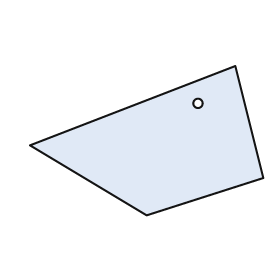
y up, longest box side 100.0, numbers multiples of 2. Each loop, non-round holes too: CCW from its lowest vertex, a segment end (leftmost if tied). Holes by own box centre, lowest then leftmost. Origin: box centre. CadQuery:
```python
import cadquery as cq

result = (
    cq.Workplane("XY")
    .moveTo(0.0, -32.0)
    .lineTo(50.0, -16.0)
    .lineTo(38.0, 32.0)
    .lineTo(-50.0, -2.0)
    .close()
    .moveTo(22.0, 16.0)
    .circle(2.0)
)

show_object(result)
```